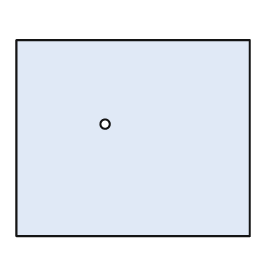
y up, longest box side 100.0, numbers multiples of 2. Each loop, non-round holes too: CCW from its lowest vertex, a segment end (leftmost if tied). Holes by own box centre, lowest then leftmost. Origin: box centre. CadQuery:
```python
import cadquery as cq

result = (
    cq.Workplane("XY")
    .moveTo(-50.0, -42.0)
    .lineTo(50.0, -42.0)
    .lineTo(50.0, 42.0)
    .lineTo(-50.0, 42.0)
    .close()
    .moveTo(-12.0, 6.0)
    .circle(2.0)
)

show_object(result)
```